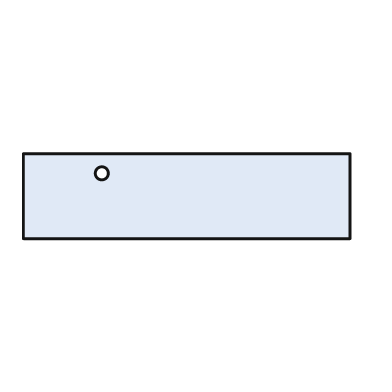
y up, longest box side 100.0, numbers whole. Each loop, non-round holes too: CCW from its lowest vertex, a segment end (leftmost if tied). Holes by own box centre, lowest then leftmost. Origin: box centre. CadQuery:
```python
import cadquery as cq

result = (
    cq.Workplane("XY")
    .moveTo(-50.0, -13.0)
    .lineTo(50.0, -13.0)
    .lineTo(50.0, 13.0)
    .lineTo(-50.0, 13.0)
    .close()
    .moveTo(-26.0, 7.0)
    .circle(2.0)
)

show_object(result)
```